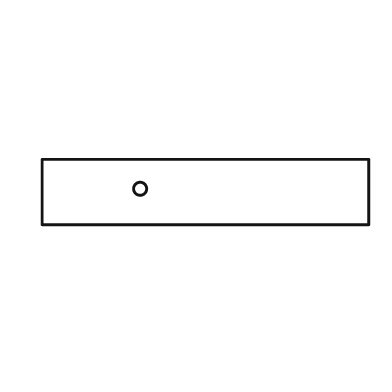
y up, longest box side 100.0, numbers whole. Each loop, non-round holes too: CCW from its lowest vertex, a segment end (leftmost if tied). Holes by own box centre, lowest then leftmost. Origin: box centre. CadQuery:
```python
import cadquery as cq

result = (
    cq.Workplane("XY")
    .moveTo(-50.0, -10.0)
    .lineTo(50.0, -10.0)
    .lineTo(50.0, 10.0)
    .lineTo(-50.0, 10.0)
    .close()
    .moveTo(-20.0, 1.0)
    .circle(2.0)
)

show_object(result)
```